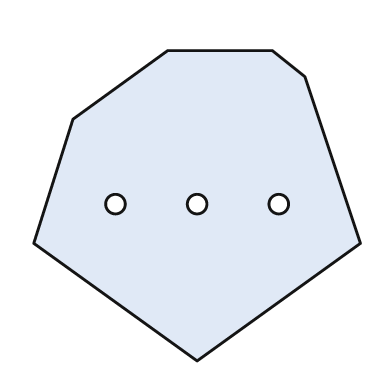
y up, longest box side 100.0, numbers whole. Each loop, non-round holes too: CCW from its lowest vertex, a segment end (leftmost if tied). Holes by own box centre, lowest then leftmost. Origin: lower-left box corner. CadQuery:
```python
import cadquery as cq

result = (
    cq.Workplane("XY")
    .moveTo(50.0, 0.0)
    .lineTo(100.0, 36.0)
    .lineTo(83.0, 87.0)
    .lineTo(73.0, 95.0)
    .lineTo(41.0, 95.0)
    .lineTo(12.0, 74.0)
    .lineTo(0.0, 36.0)
    .close()
    .moveTo(25.0, 48.0)
    .circle(3.0)
    .moveTo(50.0, 48.0)
    .circle(3.0)
    .moveTo(75.0, 48.0)
    .circle(3.0)
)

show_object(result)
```